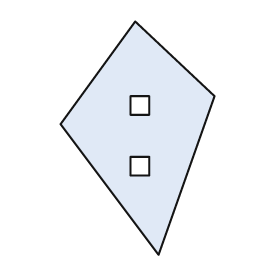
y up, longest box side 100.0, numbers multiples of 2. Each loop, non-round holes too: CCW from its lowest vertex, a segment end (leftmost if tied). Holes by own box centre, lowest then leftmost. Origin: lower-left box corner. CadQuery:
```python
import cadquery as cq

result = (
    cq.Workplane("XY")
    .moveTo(42.0, 0.0)
    .lineTo(66.0, 68.0)
    .lineTo(32.0, 100.0)
    .lineTo(0.0, 56.0)
    .close()
    .moveTo(30.0, 34.0)
    .lineTo(38.0, 34.0)
    .lineTo(38.0, 42.0)
    .lineTo(30.0, 42.0)
    .close()
    .moveTo(30.0, 60.0)
    .lineTo(38.0, 60.0)
    .lineTo(38.0, 68.0)
    .lineTo(30.0, 68.0)
    .close()
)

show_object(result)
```